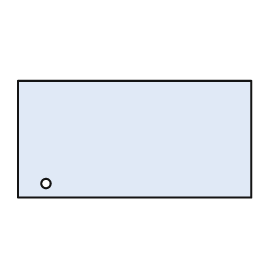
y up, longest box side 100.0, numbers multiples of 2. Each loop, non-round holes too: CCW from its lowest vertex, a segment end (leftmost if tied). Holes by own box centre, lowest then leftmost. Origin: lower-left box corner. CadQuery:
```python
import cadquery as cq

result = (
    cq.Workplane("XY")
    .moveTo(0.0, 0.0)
    .lineTo(100.0, 0.0)
    .lineTo(100.0, 50.0)
    .lineTo(0.0, 50.0)
    .close()
    .moveTo(12.0, 6.0)
    .circle(2.0)
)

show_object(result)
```